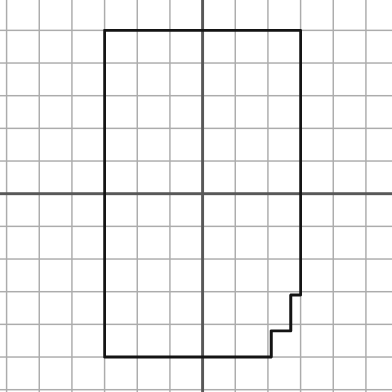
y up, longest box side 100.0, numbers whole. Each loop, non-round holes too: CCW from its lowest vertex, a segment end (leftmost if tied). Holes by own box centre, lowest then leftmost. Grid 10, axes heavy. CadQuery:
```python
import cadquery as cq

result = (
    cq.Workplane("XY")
    .moveTo(-30.0, -50.0)
    .lineTo(21.0, -50.0)
    .lineTo(21.0, -42.0)
    .lineTo(27.0, -42.0)
    .lineTo(27.0, -31.0)
    .lineTo(30.0, -31.0)
    .lineTo(30.0, 50.0)
    .lineTo(-30.0, 50.0)
    .close()
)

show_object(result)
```